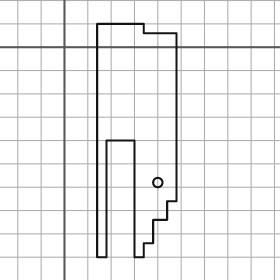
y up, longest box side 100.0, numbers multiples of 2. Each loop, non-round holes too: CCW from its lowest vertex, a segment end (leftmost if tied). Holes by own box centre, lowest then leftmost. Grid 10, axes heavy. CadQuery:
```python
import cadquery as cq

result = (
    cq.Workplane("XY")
    .moveTo(14.0, -90.0)
    .lineTo(18.0, -90.0)
    .lineTo(18.0, -40.0)
    .lineTo(30.0, -40.0)
    .lineTo(30.0, -90.0)
    .lineTo(34.0, -90.0)
    .lineTo(34.0, -84.0)
    .lineTo(38.0, -84.0)
    .lineTo(38.0, -74.0)
    .lineTo(44.0, -74.0)
    .lineTo(44.0, -66.0)
    .lineTo(48.0, -66.0)
    .lineTo(48.0, 6.0)
    .lineTo(34.0, 6.0)
    .lineTo(34.0, 10.0)
    .lineTo(14.0, 10.0)
    .close()
    .moveTo(40.0, -58.0)
    .circle(2.0)
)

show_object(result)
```